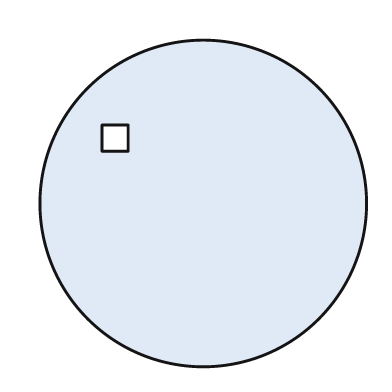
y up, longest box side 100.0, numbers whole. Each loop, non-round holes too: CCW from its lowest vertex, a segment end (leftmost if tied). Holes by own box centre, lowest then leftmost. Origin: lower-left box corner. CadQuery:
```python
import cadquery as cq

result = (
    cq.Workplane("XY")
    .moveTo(50.0, 50.0)
    .circle(50.0)
    .moveTo(19.0, 66.0)
    .lineTo(27.0, 66.0)
    .lineTo(27.0, 74.0)
    .lineTo(19.0, 74.0)
    .close()
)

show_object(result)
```